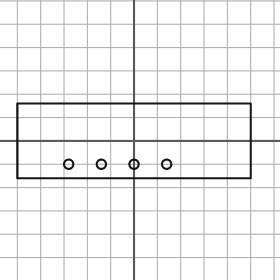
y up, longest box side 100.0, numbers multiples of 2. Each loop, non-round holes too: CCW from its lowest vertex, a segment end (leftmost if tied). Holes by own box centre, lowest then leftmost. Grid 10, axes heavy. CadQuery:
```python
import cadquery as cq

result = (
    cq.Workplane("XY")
    .moveTo(-50.0, -16.0)
    .lineTo(50.0, -16.0)
    .lineTo(50.0, 16.0)
    .lineTo(-50.0, 16.0)
    .close()
    .moveTo(-28.0, -10.0)
    .circle(2.0)
    .moveTo(-14.0, -10.0)
    .circle(2.0)
    .moveTo(0.0, -10.0)
    .circle(2.0)
    .moveTo(14.0, -10.0)
    .circle(2.0)
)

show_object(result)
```